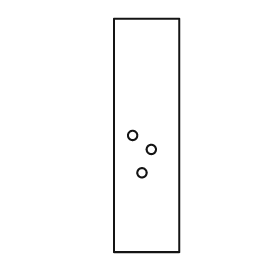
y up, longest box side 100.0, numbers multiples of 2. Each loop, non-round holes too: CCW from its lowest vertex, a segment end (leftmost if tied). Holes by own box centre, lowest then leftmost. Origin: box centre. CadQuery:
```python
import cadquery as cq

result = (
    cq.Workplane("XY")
    .moveTo(-14.0, -50.0)
    .lineTo(14.0, -50.0)
    .lineTo(14.0, 50.0)
    .lineTo(-14.0, 50.0)
    .close()
    .moveTo(-2.0, -16.0)
    .circle(2.0)
    .moveTo(2.0, -6.0)
    .circle(2.0)
    .moveTo(-6.0, 0.0)
    .circle(2.0)
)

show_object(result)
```